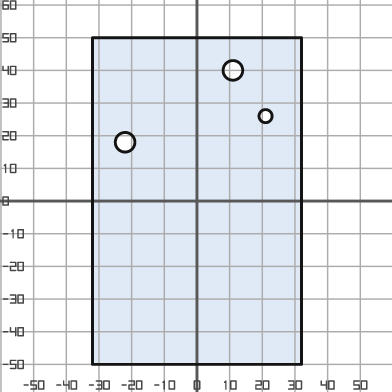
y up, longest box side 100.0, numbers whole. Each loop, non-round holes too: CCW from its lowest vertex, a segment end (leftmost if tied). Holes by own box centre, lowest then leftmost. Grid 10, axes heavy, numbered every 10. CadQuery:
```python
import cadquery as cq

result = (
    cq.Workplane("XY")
    .moveTo(-32.0, -50.0)
    .lineTo(32.0, -50.0)
    .lineTo(32.0, 50.0)
    .lineTo(-32.0, 50.0)
    .close()
    .moveTo(-22.0, 18.0)
    .circle(3.0)
    .moveTo(21.0, 26.0)
    .circle(2.0)
    .moveTo(11.0, 40.0)
    .circle(3.0)
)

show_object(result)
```